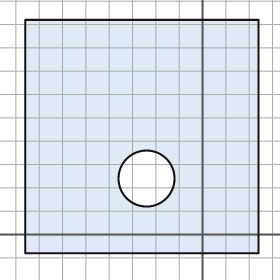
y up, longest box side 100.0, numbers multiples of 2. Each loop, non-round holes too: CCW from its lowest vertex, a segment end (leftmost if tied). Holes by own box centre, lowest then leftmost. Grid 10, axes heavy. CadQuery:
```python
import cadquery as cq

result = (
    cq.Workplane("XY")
    .moveTo(-76.0, -8.0)
    .lineTo(24.0, -8.0)
    .lineTo(24.0, 92.0)
    .lineTo(-76.0, 92.0)
    .close()
    .moveTo(-24.0, 24.0)
    .circle(12.0)
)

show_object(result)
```